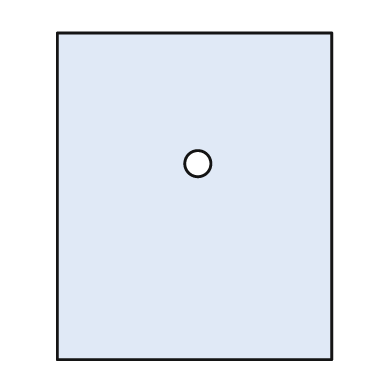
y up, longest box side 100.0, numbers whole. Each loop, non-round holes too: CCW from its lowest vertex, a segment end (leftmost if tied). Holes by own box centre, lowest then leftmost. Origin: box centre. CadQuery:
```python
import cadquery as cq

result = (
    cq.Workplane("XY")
    .moveTo(-42.0, -50.0)
    .lineTo(42.0, -50.0)
    .lineTo(42.0, 50.0)
    .lineTo(-42.0, 50.0)
    .close()
    .moveTo(1.0, 10.0)
    .circle(4.0)
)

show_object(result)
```